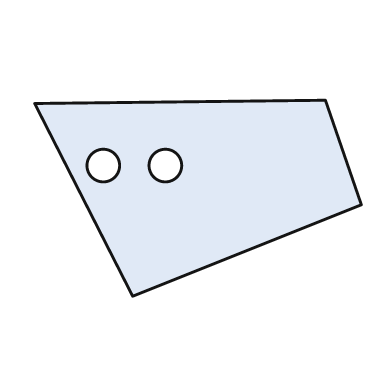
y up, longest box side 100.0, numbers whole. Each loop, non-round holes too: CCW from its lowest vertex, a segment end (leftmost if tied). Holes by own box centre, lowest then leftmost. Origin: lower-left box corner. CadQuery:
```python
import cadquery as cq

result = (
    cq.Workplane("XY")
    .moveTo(30.0, 0.0)
    .lineTo(100.0, 28.0)
    .lineTo(89.0, 60.0)
    .lineTo(0.0, 59.0)
    .close()
    .moveTo(21.0, 40.0)
    .circle(5.0)
    .moveTo(40.0, 40.0)
    .circle(5.0)
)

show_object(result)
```